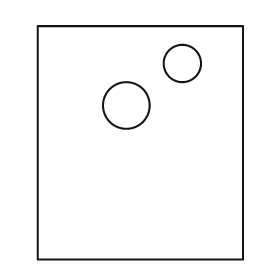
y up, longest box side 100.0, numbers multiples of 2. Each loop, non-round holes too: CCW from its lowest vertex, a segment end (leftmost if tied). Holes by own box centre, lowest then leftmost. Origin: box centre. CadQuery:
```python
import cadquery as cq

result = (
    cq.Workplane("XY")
    .moveTo(-44.0, -50.0)
    .lineTo(44.0, -50.0)
    .lineTo(44.0, 50.0)
    .lineTo(-44.0, 50.0)
    .close()
    .moveTo(-6.0, 16.0)
    .circle(10.0)
    .moveTo(18.0, 34.0)
    .circle(8.0)
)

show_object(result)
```